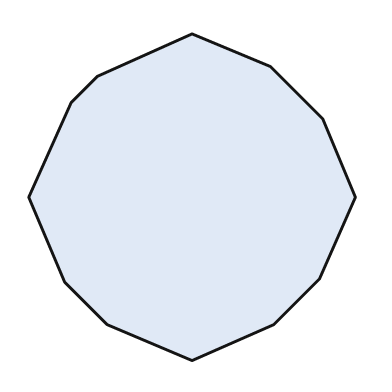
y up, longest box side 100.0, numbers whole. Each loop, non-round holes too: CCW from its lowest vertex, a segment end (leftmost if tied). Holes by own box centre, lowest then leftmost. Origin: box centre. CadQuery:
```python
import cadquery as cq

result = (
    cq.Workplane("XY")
    .moveTo(0.0, -50.0)
    .lineTo(25.0, -39.0)
    .lineTo(39.0, -25.0)
    .lineTo(50.0, 0.0)
    .lineTo(40.0, 24.0)
    .lineTo(24.0, 40.0)
    .lineTo(0.0, 50.0)
    .lineTo(-29.0, 37.0)
    .lineTo(-37.0, 29.0)
    .lineTo(-50.0, 0.0)
    .lineTo(-39.0, -26.0)
    .lineTo(-26.0, -39.0)
    .close()
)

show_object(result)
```